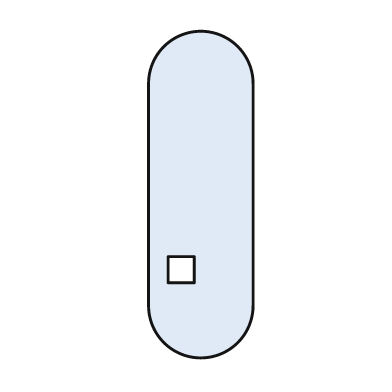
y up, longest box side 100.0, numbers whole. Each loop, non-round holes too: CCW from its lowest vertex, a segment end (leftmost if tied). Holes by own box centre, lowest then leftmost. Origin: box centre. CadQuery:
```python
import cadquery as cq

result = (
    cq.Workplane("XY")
    .moveTo(-16.0, -34.0)
    .threePointArc((0.0, -50.0), (16.0, -34.0))
    .lineTo(16.0, 34.0)
    .threePointArc((0.0, 50.0), (-16.0, 34.0))
    .close()
    .moveTo(-10.0, -27.0)
    .lineTo(-2.0, -27.0)
    .lineTo(-2.0, -19.0)
    .lineTo(-10.0, -19.0)
    .close()
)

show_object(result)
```